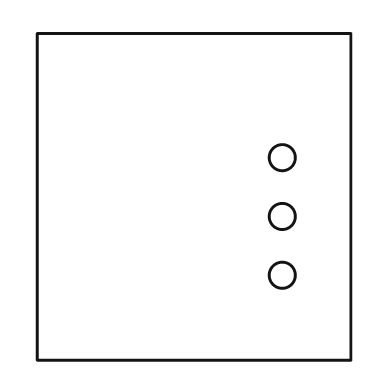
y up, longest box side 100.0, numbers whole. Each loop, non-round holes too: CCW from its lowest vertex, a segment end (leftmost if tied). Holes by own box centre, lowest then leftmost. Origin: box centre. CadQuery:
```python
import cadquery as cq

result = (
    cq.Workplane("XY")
    .moveTo(-48.0, -50.0)
    .lineTo(48.0, -50.0)
    .lineTo(48.0, 50.0)
    .lineTo(-48.0, 50.0)
    .close()
    .moveTo(27.0, -24.0)
    .circle(4.0)
    .moveTo(27.0, -6.0)
    .circle(4.0)
    .moveTo(27.0, 12.0)
    .circle(4.0)
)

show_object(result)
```